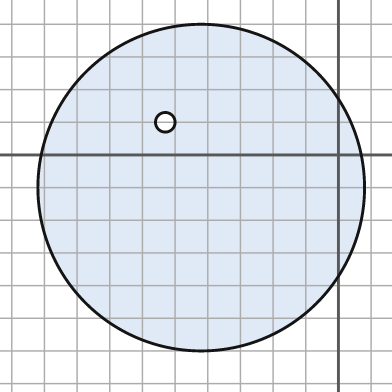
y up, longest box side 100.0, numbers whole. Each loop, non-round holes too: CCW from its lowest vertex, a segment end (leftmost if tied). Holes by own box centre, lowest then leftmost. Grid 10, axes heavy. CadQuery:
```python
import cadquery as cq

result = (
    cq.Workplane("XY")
    .moveTo(-42.0, -10.0)
    .circle(50.0)
    .moveTo(-53.0, 10.0)
    .circle(3.0)
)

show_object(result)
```